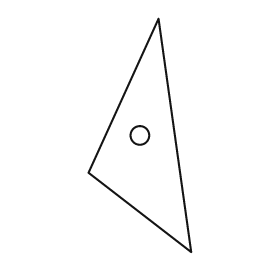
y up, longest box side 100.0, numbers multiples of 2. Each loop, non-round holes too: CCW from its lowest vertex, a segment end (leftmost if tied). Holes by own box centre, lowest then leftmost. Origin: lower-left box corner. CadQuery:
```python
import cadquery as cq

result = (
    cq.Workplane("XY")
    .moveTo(44.0, 0.0)
    .lineTo(30.0, 100.0)
    .lineTo(0.0, 34.0)
    .close()
    .moveTo(22.0, 50.0)
    .circle(4.0)
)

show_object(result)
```